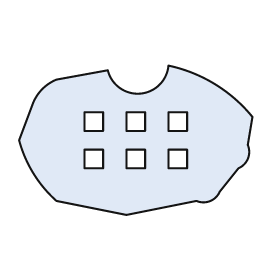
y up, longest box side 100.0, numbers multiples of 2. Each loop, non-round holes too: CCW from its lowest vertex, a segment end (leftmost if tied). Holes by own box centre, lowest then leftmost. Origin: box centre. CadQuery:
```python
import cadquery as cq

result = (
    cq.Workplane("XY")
    .moveTo(-4.0, -32.0)
    .lineTo(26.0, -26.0)
    .threePointArc((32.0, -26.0), (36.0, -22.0))
    .lineTo(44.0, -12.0)
    .threePointArc((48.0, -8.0), (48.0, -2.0))
    .lineTo(50.0, 10.0)
    .threePointArc((34.0, 24.0), (14.0, 32.0))
    .threePointArc((2.0, 20.0), (-12.0, 30.0))
    .lineTo(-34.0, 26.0)
    .threePointArc((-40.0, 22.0), (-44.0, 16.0))
    .lineTo(-50.0, 0.0)
    .threePointArc((-44.0, -14.0), (-34.0, -26.0))
    .close()
    .moveTo(-22.0, -12.0)
    .lineTo(-14.0, -12.0)
    .lineTo(-14.0, -4.0)
    .lineTo(-22.0, -4.0)
    .close()
    .moveTo(-4.0, -12.0)
    .lineTo(4.0, -12.0)
    .lineTo(4.0, -4.0)
    .lineTo(-4.0, -4.0)
    .close()
    .moveTo(14.0, -12.0)
    .lineTo(22.0, -12.0)
    .lineTo(22.0, -4.0)
    .lineTo(14.0, -4.0)
    .close()
    .moveTo(-22.0, 4.0)
    .lineTo(-14.0, 4.0)
    .lineTo(-14.0, 12.0)
    .lineTo(-22.0, 12.0)
    .close()
    .moveTo(-4.0, 4.0)
    .lineTo(4.0, 4.0)
    .lineTo(4.0, 12.0)
    .lineTo(-4.0, 12.0)
    .close()
    .moveTo(14.0, 4.0)
    .lineTo(22.0, 4.0)
    .lineTo(22.0, 12.0)
    .lineTo(14.0, 12.0)
    .close()
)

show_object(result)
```